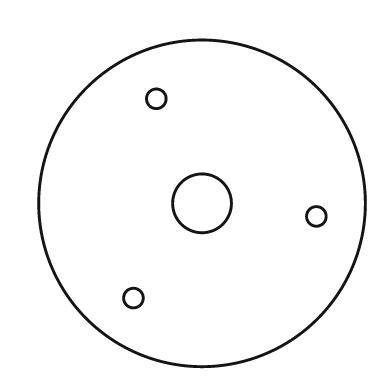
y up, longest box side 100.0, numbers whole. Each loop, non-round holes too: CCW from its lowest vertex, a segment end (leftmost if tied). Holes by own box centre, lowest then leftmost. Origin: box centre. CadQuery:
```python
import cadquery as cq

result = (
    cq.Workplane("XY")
    .moveTo(0.0, 0.0)
    .circle(50.0)
    .moveTo(-21.0, -29.0)
    .circle(3.0)
    .moveTo(35.0, -4.0)
    .circle(3.0)
    .moveTo(0.0, 0.0)
    .circle(9.0)
    .moveTo(-14.0, 32.0)
    .circle(3.0)
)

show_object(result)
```